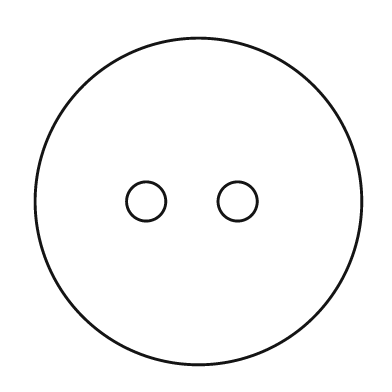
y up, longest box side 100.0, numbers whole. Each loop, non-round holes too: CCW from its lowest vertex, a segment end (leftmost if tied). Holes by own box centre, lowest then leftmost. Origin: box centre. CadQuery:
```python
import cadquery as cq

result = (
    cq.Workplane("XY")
    .moveTo(0.0, 0.0)
    .circle(50.0)
    .moveTo(-16.0, 0.0)
    .circle(6.0)
    .moveTo(12.0, 0.0)
    .circle(6.0)
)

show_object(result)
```